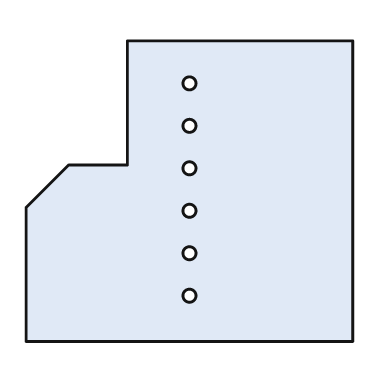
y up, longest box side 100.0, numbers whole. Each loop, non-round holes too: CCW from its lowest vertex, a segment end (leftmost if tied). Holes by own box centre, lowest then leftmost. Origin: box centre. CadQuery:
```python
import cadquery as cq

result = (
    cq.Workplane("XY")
    .moveTo(-50.0, -46.0)
    .lineTo(50.0, -46.0)
    .lineTo(50.0, 46.0)
    .lineTo(-19.0, 46.0)
    .lineTo(-19.0, 8.0)
    .lineTo(-37.0, 8.0)
    .lineTo(-50.0, -5.0)
    .close()
    .moveTo(0.0, -32.0)
    .circle(2.0)
    .moveTo(0.0, -19.0)
    .circle(2.0)
    .moveTo(0.0, -6.0)
    .circle(2.0)
    .moveTo(0.0, 7.0)
    .circle(2.0)
    .moveTo(0.0, 20.0)
    .circle(2.0)
    .moveTo(0.0, 33.0)
    .circle(2.0)
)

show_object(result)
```